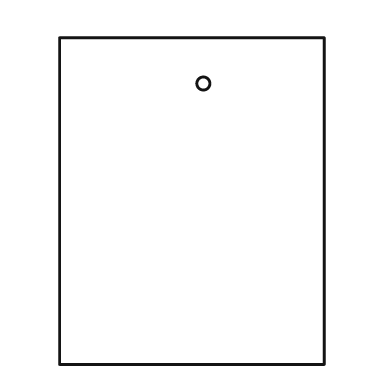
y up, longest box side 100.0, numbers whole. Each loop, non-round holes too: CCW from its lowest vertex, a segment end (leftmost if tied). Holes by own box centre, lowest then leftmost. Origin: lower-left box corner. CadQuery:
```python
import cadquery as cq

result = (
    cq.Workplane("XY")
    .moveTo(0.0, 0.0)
    .lineTo(81.0, 0.0)
    .lineTo(81.0, 100.0)
    .lineTo(0.0, 100.0)
    .close()
    .moveTo(44.0, 86.0)
    .circle(2.0)
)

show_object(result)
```